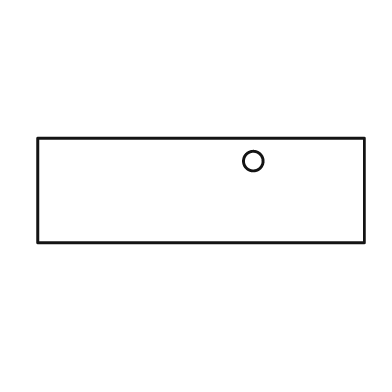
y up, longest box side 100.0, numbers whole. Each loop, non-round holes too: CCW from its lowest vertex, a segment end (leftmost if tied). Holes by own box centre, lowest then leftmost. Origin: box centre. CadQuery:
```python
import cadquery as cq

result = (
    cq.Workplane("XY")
    .moveTo(-50.0, -16.0)
    .lineTo(50.0, -16.0)
    .lineTo(50.0, 16.0)
    .lineTo(-50.0, 16.0)
    .close()
    .moveTo(16.0, 9.0)
    .circle(3.0)
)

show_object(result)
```